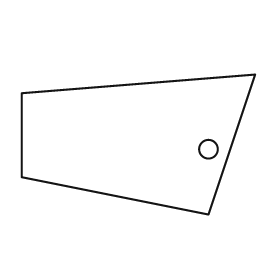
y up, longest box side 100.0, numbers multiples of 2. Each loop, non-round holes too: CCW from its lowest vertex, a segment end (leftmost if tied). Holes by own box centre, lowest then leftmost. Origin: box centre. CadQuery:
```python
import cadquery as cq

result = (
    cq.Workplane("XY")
    .moveTo(30.0, -30.0)
    .lineTo(50.0, 30.0)
    .lineTo(-50.0, 22.0)
    .lineTo(-50.0, -14.0)
    .close()
    .moveTo(30.0, -2.0)
    .circle(4.0)
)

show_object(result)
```